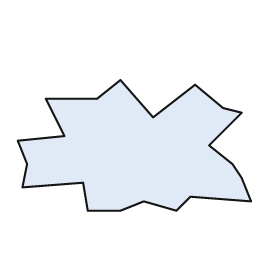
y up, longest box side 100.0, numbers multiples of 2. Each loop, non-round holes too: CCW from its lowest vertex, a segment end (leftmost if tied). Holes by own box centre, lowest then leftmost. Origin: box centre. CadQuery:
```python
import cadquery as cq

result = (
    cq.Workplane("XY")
    .moveTo(-20.0, -28.0)
    .lineTo(-6.0, -28.0)
    .lineTo(4.0, -24.0)
    .lineTo(18.0, -28.0)
    .lineTo(24.0, -22.0)
    .lineTo(50.0, -24.0)
    .lineTo(46.0, -14.0)
    .lineTo(42.0, -8.0)
    .lineTo(32.0, 0.0)
    .lineTo(46.0, 14.0)
    .lineTo(38.0, 16.0)
    .lineTo(26.0, 26.0)
    .lineTo(8.0, 12.0)
    .lineTo(-6.0, 28.0)
    .lineTo(-16.0, 20.0)
    .lineTo(-38.0, 20.0)
    .lineTo(-30.0, 4.0)
    .lineTo(-50.0, 2.0)
    .lineTo(-46.0, -8.0)
    .lineTo(-48.0, -18.0)
    .lineTo(-22.0, -16.0)
    .close()
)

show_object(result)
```